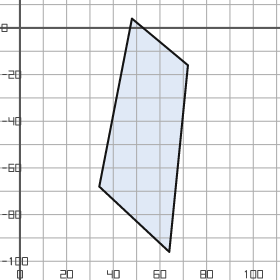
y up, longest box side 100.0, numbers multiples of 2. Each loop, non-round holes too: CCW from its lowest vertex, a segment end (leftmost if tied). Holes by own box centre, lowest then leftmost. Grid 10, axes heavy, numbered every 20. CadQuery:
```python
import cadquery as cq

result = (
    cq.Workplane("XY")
    .moveTo(64.0, -96.0)
    .lineTo(72.0, -16.0)
    .lineTo(48.0, 4.0)
    .lineTo(34.0, -68.0)
    .close()
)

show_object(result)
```